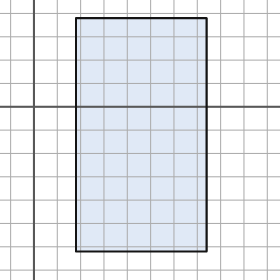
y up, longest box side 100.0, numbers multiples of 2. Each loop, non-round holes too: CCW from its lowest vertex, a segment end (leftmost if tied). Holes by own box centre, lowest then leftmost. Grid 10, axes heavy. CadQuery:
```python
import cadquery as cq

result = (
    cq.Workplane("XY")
    .moveTo(18.0, -62.0)
    .lineTo(74.0, -62.0)
    .lineTo(74.0, 38.0)
    .lineTo(18.0, 38.0)
    .close()
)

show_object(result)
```